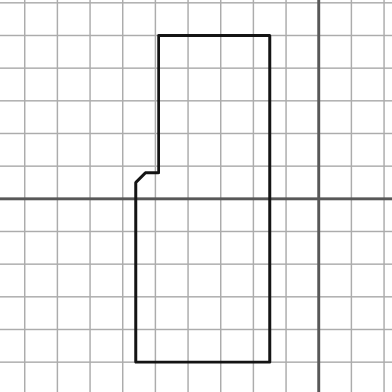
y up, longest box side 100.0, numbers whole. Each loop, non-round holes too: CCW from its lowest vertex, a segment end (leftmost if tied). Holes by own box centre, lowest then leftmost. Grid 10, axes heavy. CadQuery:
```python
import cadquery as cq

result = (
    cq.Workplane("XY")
    .moveTo(-56.0, -50.0)
    .lineTo(-15.0, -50.0)
    .lineTo(-15.0, 50.0)
    .lineTo(-49.0, 50.0)
    .lineTo(-49.0, 8.0)
    .lineTo(-53.0, 8.0)
    .lineTo(-56.0, 5.0)
    .close()
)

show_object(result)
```